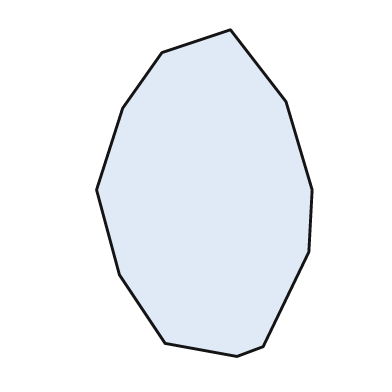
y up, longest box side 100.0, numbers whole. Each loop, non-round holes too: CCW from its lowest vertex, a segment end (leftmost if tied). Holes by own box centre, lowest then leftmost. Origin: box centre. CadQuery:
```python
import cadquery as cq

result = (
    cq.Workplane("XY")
    .moveTo(10.0, -50.0)
    .lineTo(18.0, -47.0)
    .lineTo(32.0, -18.0)
    .lineTo(33.0, 1.0)
    .lineTo(25.0, 28.0)
    .lineTo(8.0, 50.0)
    .lineTo(-13.0, 43.0)
    .lineTo(-25.0, 26.0)
    .lineTo(-33.0, 1.0)
    .lineTo(-26.0, -25.0)
    .lineTo(-12.0, -46.0)
    .close()
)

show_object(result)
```